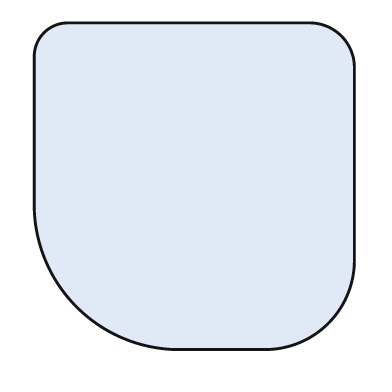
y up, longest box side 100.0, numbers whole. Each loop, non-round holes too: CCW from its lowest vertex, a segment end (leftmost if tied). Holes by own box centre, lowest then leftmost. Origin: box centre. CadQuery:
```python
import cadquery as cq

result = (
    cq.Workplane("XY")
    .moveTo(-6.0, -50.0)
    .lineTo(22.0, -50.0)
    .threePointArc((41.0, -42.0), (49.0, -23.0))
    .lineTo(49.0, 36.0)
    .threePointArc((45.0, 46.0), (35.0, 50.0))
    .lineTo(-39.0, 50.0)
    .threePointArc((-46.0, 47.0), (-49.0, 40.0))
    .lineTo(-49.0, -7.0)
    .threePointArc((-36.0, -37.0), (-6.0, -50.0))
    .close()
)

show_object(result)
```